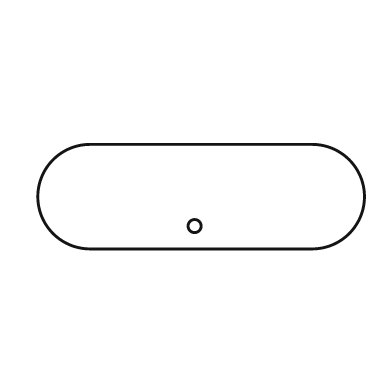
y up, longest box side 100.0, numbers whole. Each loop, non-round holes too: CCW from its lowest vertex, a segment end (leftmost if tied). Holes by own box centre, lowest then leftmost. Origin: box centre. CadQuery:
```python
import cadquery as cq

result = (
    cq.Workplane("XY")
    .moveTo(-34.0, -16.0)
    .lineTo(34.0, -16.0)
    .threePointArc((50.0, 0.0), (34.0, 16.0))
    .lineTo(-34.0, 16.0)
    .threePointArc((-50.0, 0.0), (-34.0, -16.0))
    .close()
    .moveTo(-2.0, -9.0)
    .circle(2.0)
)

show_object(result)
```